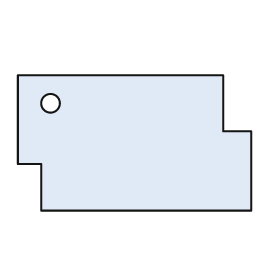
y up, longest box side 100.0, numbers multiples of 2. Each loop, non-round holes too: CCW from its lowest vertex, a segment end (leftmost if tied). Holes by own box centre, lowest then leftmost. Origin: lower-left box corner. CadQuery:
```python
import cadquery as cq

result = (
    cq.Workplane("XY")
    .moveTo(10.0, 0.0)
    .lineTo(100.0, 0.0)
    .lineTo(100.0, 34.0)
    .lineTo(88.0, 34.0)
    .lineTo(88.0, 58.0)
    .lineTo(0.0, 58.0)
    .lineTo(0.0, 20.0)
    .lineTo(10.0, 20.0)
    .close()
    .moveTo(14.0, 46.0)
    .circle(4.0)
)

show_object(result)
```